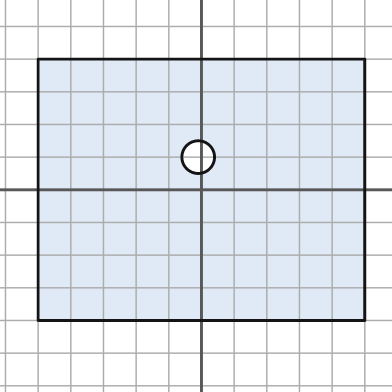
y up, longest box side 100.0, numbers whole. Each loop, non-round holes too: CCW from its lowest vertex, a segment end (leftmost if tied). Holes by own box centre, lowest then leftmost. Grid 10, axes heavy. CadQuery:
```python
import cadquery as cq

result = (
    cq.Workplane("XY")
    .moveTo(-50.0, -40.0)
    .lineTo(50.0, -40.0)
    .lineTo(50.0, 40.0)
    .lineTo(-50.0, 40.0)
    .close()
    .moveTo(-1.0, 10.0)
    .circle(5.0)
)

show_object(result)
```